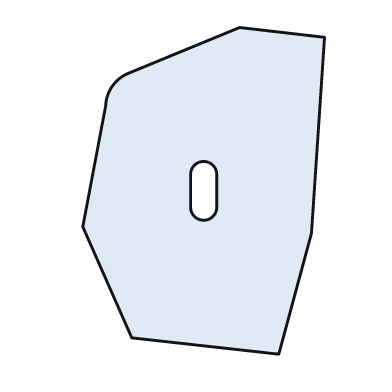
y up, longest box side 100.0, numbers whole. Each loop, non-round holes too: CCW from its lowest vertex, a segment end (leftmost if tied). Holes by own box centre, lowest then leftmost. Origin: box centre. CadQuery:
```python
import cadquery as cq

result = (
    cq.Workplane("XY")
    .moveTo(23.0, -50.0)
    .lineTo(33.0, -13.0)
    .lineTo(37.0, 47.0)
    .lineTo(11.0, 50.0)
    .lineTo(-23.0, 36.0)
    .threePointArc((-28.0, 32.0), (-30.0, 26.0))
    .lineTo(-37.0, -11.0)
    .lineTo(-22.0, -45.0)
    .close()
    .moveTo(-4.0, -5.0)
    .threePointArc((0.0, -9.0), (4.0, -5.0))
    .lineTo(4.0, 5.0)
    .threePointArc((0.0, 9.0), (-4.0, 5.0))
    .close()
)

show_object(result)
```